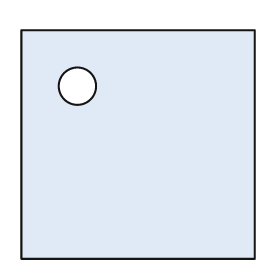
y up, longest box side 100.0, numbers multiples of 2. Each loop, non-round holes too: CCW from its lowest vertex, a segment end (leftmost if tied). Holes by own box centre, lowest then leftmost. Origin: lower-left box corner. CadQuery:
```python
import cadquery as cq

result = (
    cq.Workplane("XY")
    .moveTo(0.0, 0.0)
    .lineTo(100.0, 0.0)
    .lineTo(100.0, 98.0)
    .lineTo(0.0, 98.0)
    .close()
    .moveTo(24.0, 74.0)
    .circle(8.0)
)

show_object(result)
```